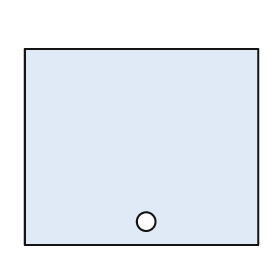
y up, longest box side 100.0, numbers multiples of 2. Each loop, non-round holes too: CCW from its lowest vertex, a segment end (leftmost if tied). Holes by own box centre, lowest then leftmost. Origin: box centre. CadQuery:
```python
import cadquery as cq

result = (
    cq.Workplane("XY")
    .moveTo(-50.0, -42.0)
    .lineTo(50.0, -42.0)
    .lineTo(50.0, 42.0)
    .lineTo(-50.0, 42.0)
    .close()
    .moveTo(2.0, -32.0)
    .circle(4.0)
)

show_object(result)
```